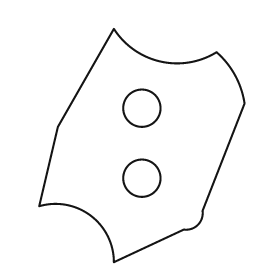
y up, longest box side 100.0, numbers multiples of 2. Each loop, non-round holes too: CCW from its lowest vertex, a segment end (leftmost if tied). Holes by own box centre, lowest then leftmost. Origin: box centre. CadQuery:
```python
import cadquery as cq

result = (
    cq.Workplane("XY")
    .moveTo(-12.0, -50.0)
    .lineTo(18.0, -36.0)
    .threePointArc((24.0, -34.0), (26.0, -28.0))
    .lineTo(44.0, 18.0)
    .threePointArc((40.0, 30.0), (32.0, 40.0))
    .threePointArc((8.0, 36.0), (-12.0, 50.0))
    .lineTo(-36.0, 8.0)
    .lineTo(-44.0, -26.0)
    .threePointArc((-22.0, -30.0), (-12.0, -50.0))
    .close()
    .moveTo(0.0, -14.0)
    .circle(8.0)
    .moveTo(0.0, 16.0)
    .circle(8.0)
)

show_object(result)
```